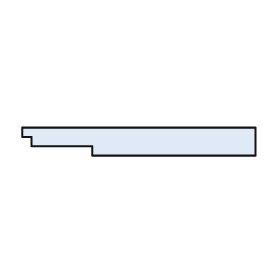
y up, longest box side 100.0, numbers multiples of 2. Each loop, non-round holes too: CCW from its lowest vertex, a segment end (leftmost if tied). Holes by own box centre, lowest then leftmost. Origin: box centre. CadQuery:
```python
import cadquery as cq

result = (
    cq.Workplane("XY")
    .moveTo(-20.0, -6.0)
    .lineTo(50.0, -6.0)
    .lineTo(50.0, 6.0)
    .lineTo(-50.0, 6.0)
    .lineTo(-50.0, 2.0)
    .lineTo(-46.0, 2.0)
    .lineTo(-46.0, -2.0)
    .lineTo(-20.0, -2.0)
    .close()
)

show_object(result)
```